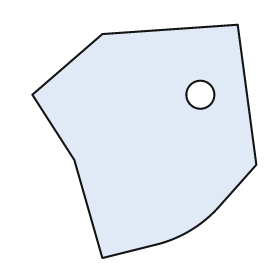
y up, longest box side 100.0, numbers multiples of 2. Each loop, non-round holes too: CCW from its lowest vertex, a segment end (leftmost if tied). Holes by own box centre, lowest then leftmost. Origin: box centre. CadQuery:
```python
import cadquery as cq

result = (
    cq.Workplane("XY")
    .moveTo(-18.0, -50.0)
    .lineTo(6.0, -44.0)
    .threePointArc((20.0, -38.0), (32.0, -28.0))
    .lineTo(48.0, -10.0)
    .lineTo(40.0, 50.0)
    .lineTo(-18.0, 46.0)
    .lineTo(-48.0, 20.0)
    .lineTo(-30.0, -8.0)
    .close()
    .moveTo(24.0, 20.0)
    .circle(6.0)
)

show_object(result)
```